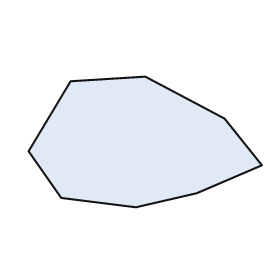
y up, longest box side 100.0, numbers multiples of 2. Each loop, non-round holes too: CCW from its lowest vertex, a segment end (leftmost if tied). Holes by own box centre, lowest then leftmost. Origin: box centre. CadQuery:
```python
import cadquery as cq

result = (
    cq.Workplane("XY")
    .moveTo(-4.0, -28.0)
    .lineTo(22.0, -22.0)
    .lineTo(50.0, -10.0)
    .lineTo(34.0, 10.0)
    .lineTo(0.0, 28.0)
    .lineTo(-32.0, 26.0)
    .lineTo(-50.0, -4.0)
    .lineTo(-36.0, -24.0)
    .close()
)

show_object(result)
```